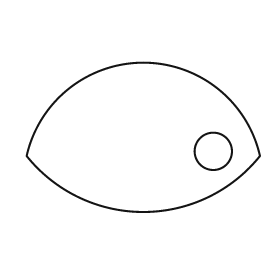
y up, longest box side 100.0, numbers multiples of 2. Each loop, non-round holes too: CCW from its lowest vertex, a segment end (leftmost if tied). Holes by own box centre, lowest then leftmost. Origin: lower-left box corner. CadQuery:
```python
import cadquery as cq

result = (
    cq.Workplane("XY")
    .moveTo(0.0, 24.0)
    .threePointArc((50.0, 0.0), (100.0, 24.0))
    .threePointArc((50.0, 64.0), (0.0, 24.0))
    .close()
    .moveTo(80.0, 26.0)
    .circle(8.0)
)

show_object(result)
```